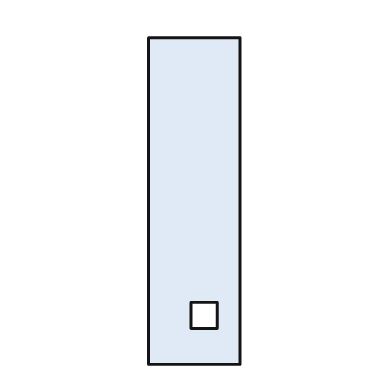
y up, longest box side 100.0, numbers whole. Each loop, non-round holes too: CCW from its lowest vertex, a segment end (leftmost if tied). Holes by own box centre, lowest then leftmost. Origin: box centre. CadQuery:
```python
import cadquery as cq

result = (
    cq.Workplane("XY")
    .moveTo(-14.0, -50.0)
    .lineTo(14.0, -50.0)
    .lineTo(14.0, 50.0)
    .lineTo(-14.0, 50.0)
    .close()
    .moveTo(-1.0, -39.0)
    .lineTo(7.0, -39.0)
    .lineTo(7.0, -31.0)
    .lineTo(-1.0, -31.0)
    .close()
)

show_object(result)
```